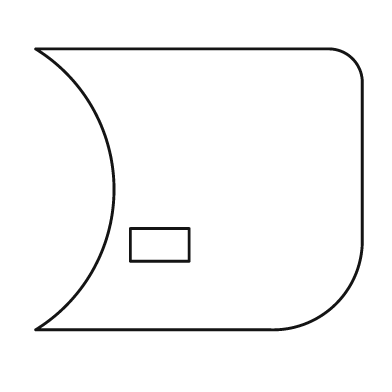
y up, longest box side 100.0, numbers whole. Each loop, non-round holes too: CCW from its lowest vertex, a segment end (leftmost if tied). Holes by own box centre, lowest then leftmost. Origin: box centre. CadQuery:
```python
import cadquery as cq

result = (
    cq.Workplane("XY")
    .moveTo(-50.0, -43.0)
    .lineTo(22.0, -43.0)
    .threePointArc((42.0, -35.0), (50.0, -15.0))
    .lineTo(50.0, 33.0)
    .threePointArc((47.0, 40.0), (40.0, 43.0))
    .lineTo(-50.0, 43.0)
    .threePointArc((-26.0, 0.0), (-50.0, -43.0))
    .close()
    .moveTo(-21.0, -22.0)
    .lineTo(-3.0, -22.0)
    .lineTo(-3.0, -12.0)
    .lineTo(-21.0, -12.0)
    .close()
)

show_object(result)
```